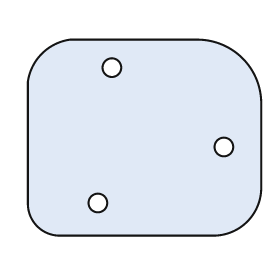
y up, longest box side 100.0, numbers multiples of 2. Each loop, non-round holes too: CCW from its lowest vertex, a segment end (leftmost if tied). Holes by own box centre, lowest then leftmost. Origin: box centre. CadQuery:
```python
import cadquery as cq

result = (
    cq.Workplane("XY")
    .moveTo(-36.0, -42.0)
    .lineTo(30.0, -42.0)
    .threePointArc((44.0, -36.0), (50.0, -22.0))
    .lineTo(50.0, 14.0)
    .threePointArc((42.0, 34.0), (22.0, 42.0))
    .lineTo(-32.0, 42.0)
    .threePointArc((-44.0, 36.0), (-50.0, 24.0))
    .lineTo(-50.0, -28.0)
    .threePointArc((-46.0, -38.0), (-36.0, -42.0))
    .close()
    .moveTo(-20.0, -28.0)
    .circle(4.0)
    .moveTo(34.0, -4.0)
    .circle(4.0)
    .moveTo(-14.0, 30.0)
    .circle(4.0)
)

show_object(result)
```